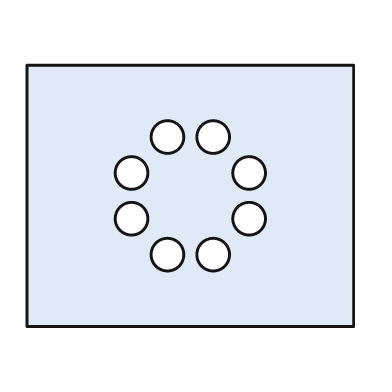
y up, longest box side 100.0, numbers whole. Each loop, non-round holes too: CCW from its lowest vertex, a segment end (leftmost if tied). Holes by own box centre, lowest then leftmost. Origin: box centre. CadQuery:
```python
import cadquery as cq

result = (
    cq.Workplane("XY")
    .moveTo(-50.0, -40.0)
    .lineTo(50.0, -40.0)
    .lineTo(50.0, 40.0)
    .lineTo(-50.0, 40.0)
    .close()
    .moveTo(-7.0, -18.0)
    .circle(5.0)
    .moveTo(7.0, -18.0)
    .circle(5.0)
    .moveTo(-18.0, -7.0)
    .circle(5.0)
    .moveTo(18.0, -7.0)
    .circle(5.0)
    .moveTo(-18.0, 7.0)
    .circle(5.0)
    .moveTo(18.0, 7.0)
    .circle(5.0)
    .moveTo(-7.0, 18.0)
    .circle(5.0)
    .moveTo(7.0, 18.0)
    .circle(5.0)
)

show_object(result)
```